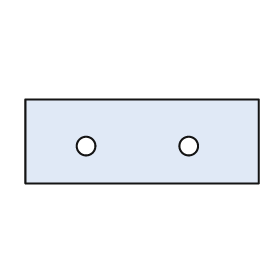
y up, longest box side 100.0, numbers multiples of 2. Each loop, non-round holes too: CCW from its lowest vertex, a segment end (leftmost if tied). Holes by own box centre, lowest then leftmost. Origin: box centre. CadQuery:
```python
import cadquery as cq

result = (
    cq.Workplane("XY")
    .moveTo(-50.0, -18.0)
    .lineTo(50.0, -18.0)
    .lineTo(50.0, 18.0)
    .lineTo(-50.0, 18.0)
    .close()
    .moveTo(-24.0, -2.0)
    .circle(4.0)
    .moveTo(20.0, -2.0)
    .circle(4.0)
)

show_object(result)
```